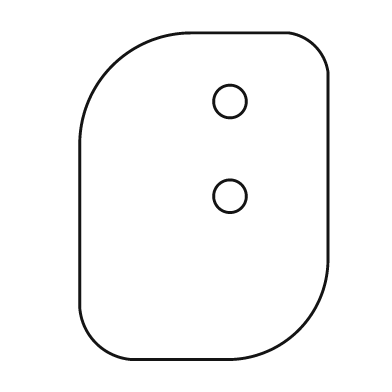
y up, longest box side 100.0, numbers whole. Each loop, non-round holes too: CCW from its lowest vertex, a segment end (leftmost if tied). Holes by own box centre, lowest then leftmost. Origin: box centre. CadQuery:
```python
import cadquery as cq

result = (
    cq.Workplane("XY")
    .moveTo(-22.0, -50.0)
    .lineTo(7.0, -50.0)
    .threePointArc((29.0, -41.0), (38.0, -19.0))
    .lineTo(38.0, 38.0)
    .threePointArc((34.0, 46.0), (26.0, 50.0))
    .lineTo(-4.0, 50.0)
    .threePointArc((-28.0, 40.0), (-38.0, 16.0))
    .lineTo(-38.0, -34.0)
    .threePointArc((-33.0, -45.0), (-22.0, -50.0))
    .close()
    .moveTo(8.0, 0.0)
    .circle(5.0)
    .moveTo(8.0, 29.0)
    .circle(5.0)
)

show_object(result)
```